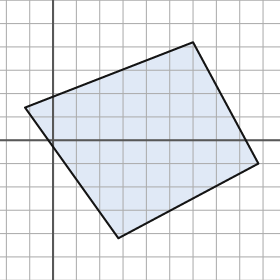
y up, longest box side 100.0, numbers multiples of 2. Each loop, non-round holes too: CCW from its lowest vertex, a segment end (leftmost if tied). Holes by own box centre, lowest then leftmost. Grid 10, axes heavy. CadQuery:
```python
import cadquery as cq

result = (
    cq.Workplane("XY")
    .moveTo(28.0, -42.0)
    .lineTo(88.0, -10.0)
    .lineTo(60.0, 42.0)
    .lineTo(-12.0, 14.0)
    .close()
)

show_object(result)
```